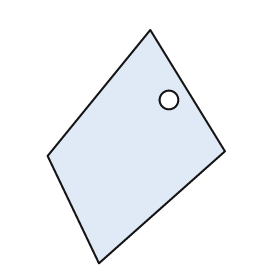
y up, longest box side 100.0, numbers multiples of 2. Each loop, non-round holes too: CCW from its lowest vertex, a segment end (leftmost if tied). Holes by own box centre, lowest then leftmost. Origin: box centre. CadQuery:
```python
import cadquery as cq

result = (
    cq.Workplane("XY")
    .moveTo(-16.0, -50.0)
    .lineTo(38.0, -2.0)
    .lineTo(6.0, 50.0)
    .lineTo(-38.0, -4.0)
    .close()
    .moveTo(14.0, 20.0)
    .circle(4.0)
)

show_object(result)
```